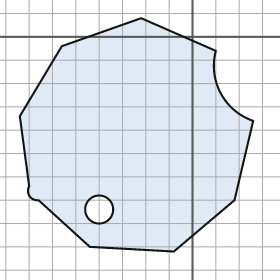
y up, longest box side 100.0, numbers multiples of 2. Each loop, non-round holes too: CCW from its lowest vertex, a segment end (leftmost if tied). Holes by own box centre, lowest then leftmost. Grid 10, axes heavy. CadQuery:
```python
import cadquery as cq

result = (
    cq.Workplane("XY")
    .moveTo(-8.0, -92.0)
    .lineTo(18.0, -70.0)
    .lineTo(26.0, -36.0)
    .threePointArc((12.0, -24.0), (10.0, -6.0))
    .lineTo(-22.0, 8.0)
    .lineTo(-56.0, -4.0)
    .lineTo(-74.0, -34.0)
    .lineTo(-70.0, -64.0)
    .threePointArc((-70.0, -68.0), (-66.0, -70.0))
    .lineTo(-44.0, -90.0)
    .close()
    .moveTo(-40.0, -74.0)
    .circle(6.0)
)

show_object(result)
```